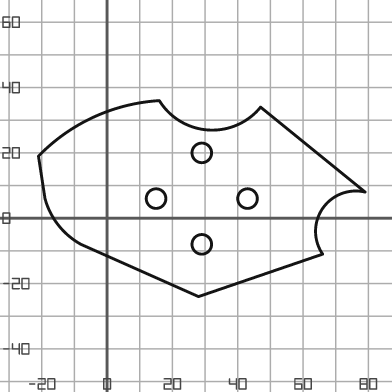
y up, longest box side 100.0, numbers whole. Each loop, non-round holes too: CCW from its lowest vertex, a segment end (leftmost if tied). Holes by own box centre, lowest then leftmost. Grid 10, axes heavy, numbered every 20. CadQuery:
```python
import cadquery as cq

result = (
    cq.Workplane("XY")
    .moveTo(28.0, -24.0)
    .lineTo(66.0, -11.0)
    .threePointArc((66.0, 3.0), (79.0, 8.0))
    .lineTo(47.0, 34.0)
    .threePointArc((31.0, 27.0), (16.0, 36.0))
    .threePointArc((-4.0, 31.0), (-21.0, 19.0))
    .lineTo(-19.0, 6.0)
    .threePointArc((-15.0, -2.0), (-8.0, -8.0))
    .close()
    .moveTo(29.0, -8.0)
    .circle(3.0)
    .moveTo(15.0, 6.0)
    .circle(3.0)
    .moveTo(43.0, 6.0)
    .circle(3.0)
    .moveTo(29.0, 20.0)
    .circle(3.0)
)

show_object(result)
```